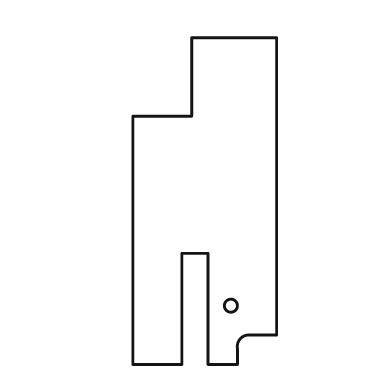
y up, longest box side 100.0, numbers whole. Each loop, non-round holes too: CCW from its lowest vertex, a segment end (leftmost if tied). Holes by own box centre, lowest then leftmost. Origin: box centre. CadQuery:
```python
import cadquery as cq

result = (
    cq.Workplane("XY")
    .moveTo(-22.0, -50.0)
    .lineTo(-7.0, -50.0)
    .lineTo(-7.0, -16.0)
    .lineTo(1.0, -16.0)
    .lineTo(1.0, -50.0)
    .lineTo(10.0, -50.0)
    .lineTo(10.0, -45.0)
    .threePointArc((11.0, -42.0), (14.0, -41.0))
    .lineTo(22.0, -41.0)
    .lineTo(22.0, 50.0)
    .lineTo(-4.0, 50.0)
    .lineTo(-4.0, 26.0)
    .lineTo(-22.0, 26.0)
    .close()
    .moveTo(8.0, -32.0)
    .circle(2.0)
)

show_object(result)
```